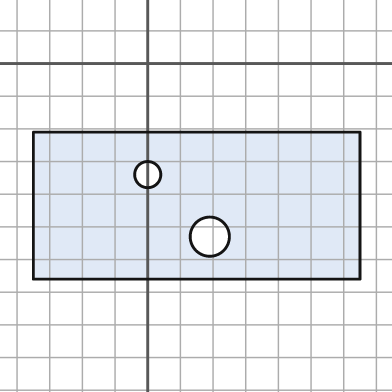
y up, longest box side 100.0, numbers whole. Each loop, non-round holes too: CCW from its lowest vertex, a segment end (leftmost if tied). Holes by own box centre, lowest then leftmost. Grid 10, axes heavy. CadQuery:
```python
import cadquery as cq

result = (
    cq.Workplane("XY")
    .moveTo(-35.0, -66.0)
    .lineTo(65.0, -66.0)
    .lineTo(65.0, -21.0)
    .lineTo(-35.0, -21.0)
    .close()
    .moveTo(19.0, -53.0)
    .circle(6.0)
    .moveTo(0.0, -34.0)
    .circle(4.0)
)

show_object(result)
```